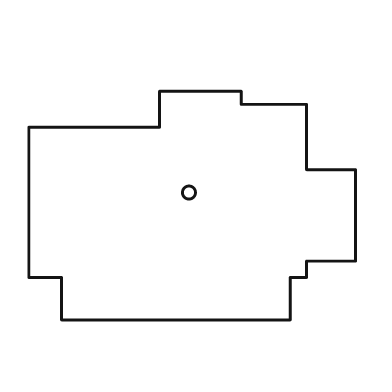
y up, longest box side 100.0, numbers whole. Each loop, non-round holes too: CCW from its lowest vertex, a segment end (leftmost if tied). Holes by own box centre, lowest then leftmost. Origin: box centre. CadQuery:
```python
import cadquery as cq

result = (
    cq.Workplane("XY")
    .moveTo(-40.0, -35.0)
    .lineTo(30.0, -35.0)
    .lineTo(30.0, -22.0)
    .lineTo(35.0, -22.0)
    .lineTo(35.0, -17.0)
    .lineTo(50.0, -17.0)
    .lineTo(50.0, 11.0)
    .lineTo(35.0, 11.0)
    .lineTo(35.0, 31.0)
    .lineTo(15.0, 31.0)
    .lineTo(15.0, 35.0)
    .lineTo(-10.0, 35.0)
    .lineTo(-10.0, 24.0)
    .lineTo(-50.0, 24.0)
    .lineTo(-50.0, -22.0)
    .lineTo(-40.0, -22.0)
    .close()
    .moveTo(-1.0, 4.0)
    .circle(2.0)
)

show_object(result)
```